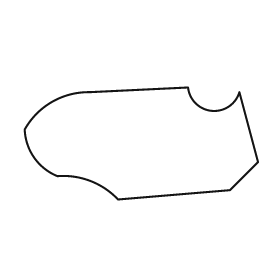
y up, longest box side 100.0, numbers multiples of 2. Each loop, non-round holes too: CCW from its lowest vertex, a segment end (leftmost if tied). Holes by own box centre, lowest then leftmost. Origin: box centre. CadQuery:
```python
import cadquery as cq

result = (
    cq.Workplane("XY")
    .moveTo(-10.0, -24.0)
    .lineTo(38.0, -20.0)
    .lineTo(50.0, -8.0)
    .lineTo(42.0, 22.0)
    .threePointArc((30.0, 14.0), (20.0, 24.0))
    .lineTo(-22.0, 22.0)
    .threePointArc((-38.0, 18.0), (-50.0, 6.0))
    .threePointArc((-46.0, -6.0), (-36.0, -14.0))
    .threePointArc((-22.0, -16.0), (-10.0, -24.0))
    .close()
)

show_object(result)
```